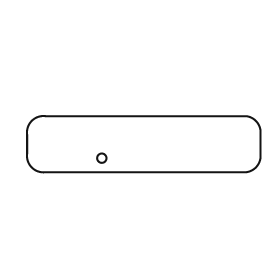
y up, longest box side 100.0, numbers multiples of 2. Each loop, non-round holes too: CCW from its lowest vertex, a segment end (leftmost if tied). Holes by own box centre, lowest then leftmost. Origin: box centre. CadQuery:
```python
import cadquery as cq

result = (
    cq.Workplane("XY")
    .moveTo(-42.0, -12.0)
    .lineTo(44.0, -12.0)
    .threePointArc((48.0, -10.0), (50.0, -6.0))
    .lineTo(50.0, 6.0)
    .threePointArc((48.0, 10.0), (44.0, 12.0))
    .lineTo(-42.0, 12.0)
    .threePointArc((-48.0, 10.0), (-50.0, 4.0))
    .lineTo(-50.0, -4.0)
    .threePointArc((-48.0, -10.0), (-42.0, -12.0))
    .close()
    .moveTo(-18.0, -6.0)
    .circle(2.0)
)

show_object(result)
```